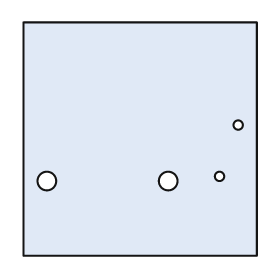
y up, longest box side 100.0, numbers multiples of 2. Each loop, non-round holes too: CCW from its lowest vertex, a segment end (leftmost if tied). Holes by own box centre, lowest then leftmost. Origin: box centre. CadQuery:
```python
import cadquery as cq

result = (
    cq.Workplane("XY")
    .moveTo(-50.0, -50.0)
    .lineTo(50.0, -50.0)
    .lineTo(50.0, 50.0)
    .lineTo(-50.0, 50.0)
    .close()
    .moveTo(-40.0, -18.0)
    .circle(4.0)
    .moveTo(12.0, -18.0)
    .circle(4.0)
    .moveTo(34.0, -16.0)
    .circle(2.0)
    .moveTo(42.0, 6.0)
    .circle(2.0)
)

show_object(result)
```